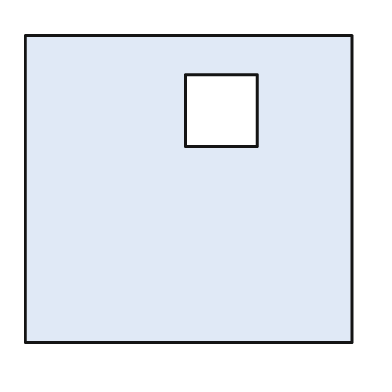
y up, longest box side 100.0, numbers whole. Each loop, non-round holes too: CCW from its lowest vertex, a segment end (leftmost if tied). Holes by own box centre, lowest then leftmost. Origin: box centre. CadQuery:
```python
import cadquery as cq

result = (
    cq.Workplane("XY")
    .moveTo(-50.0, -47.0)
    .lineTo(50.0, -47.0)
    .lineTo(50.0, 47.0)
    .lineTo(-50.0, 47.0)
    .close()
    .moveTo(-1.0, 13.0)
    .lineTo(21.0, 13.0)
    .lineTo(21.0, 35.0)
    .lineTo(-1.0, 35.0)
    .close()
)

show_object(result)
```